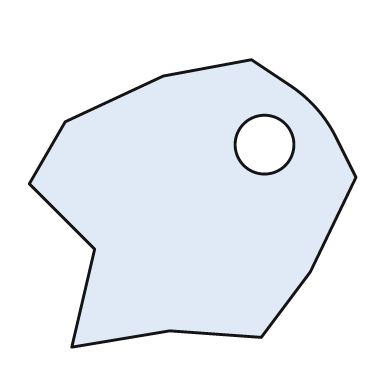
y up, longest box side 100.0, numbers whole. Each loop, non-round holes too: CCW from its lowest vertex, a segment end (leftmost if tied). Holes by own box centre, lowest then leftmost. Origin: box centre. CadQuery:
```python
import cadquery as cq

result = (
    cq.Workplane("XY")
    .moveTo(-37.0, -44.0)
    .lineTo(-7.0, -39.0)
    .lineTo(21.0, -41.0)
    .lineTo(36.0, -21.0)
    .lineTo(50.0, 8.0)
    .lineTo(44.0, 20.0)
    .threePointArc((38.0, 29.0), (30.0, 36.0))
    .lineTo(18.0, 44.0)
    .lineTo(-9.0, 39.0)
    .lineTo(-39.0, 25.0)
    .lineTo(-50.0, 6.0)
    .lineTo(-30.0, -14.0)
    .close()
    .moveTo(22.0, 18.0)
    .circle(9.0)
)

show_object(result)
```